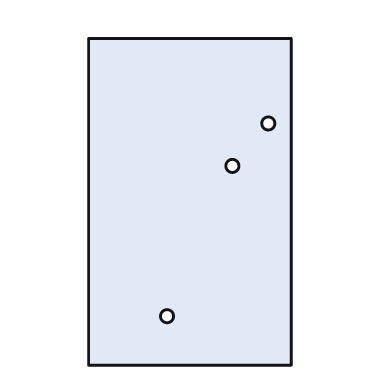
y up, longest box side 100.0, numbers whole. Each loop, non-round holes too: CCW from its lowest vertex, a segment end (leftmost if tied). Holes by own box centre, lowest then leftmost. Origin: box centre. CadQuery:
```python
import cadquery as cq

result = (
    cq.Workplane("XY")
    .moveTo(-31.0, -50.0)
    .lineTo(31.0, -50.0)
    .lineTo(31.0, 50.0)
    .lineTo(-31.0, 50.0)
    .close()
    .moveTo(-7.0, -35.0)
    .circle(2.0)
    .moveTo(13.0, 11.0)
    .circle(2.0)
    .moveTo(24.0, 24.0)
    .circle(2.0)
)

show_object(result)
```